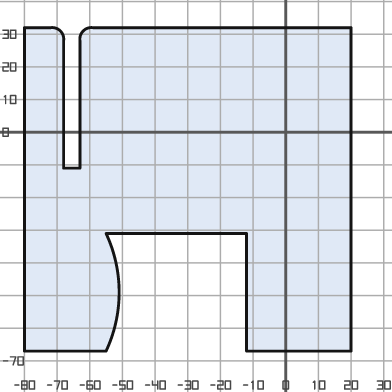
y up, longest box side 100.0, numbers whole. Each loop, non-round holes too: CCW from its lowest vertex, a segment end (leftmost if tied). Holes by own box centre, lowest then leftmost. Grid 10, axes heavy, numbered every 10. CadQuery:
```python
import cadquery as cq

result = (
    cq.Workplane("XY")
    .moveTo(-80.0, -67.0)
    .lineTo(-55.0, -67.0)
    .threePointArc((-51.0, -49.0), (-55.0, -31.0))
    .lineTo(-12.0, -31.0)
    .lineTo(-12.0, -67.0)
    .lineTo(20.0, -67.0)
    .lineTo(20.0, 32.0)
    .lineTo(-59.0, 32.0)
    .threePointArc((-62.0, 31.0), (-63.0, 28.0))
    .lineTo(-63.0, -11.0)
    .lineTo(-68.0, -11.0)
    .lineTo(-68.0, 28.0)
    .threePointArc((-69.0, 31.0), (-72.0, 32.0))
    .lineTo(-80.0, 32.0)
    .close()
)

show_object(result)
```